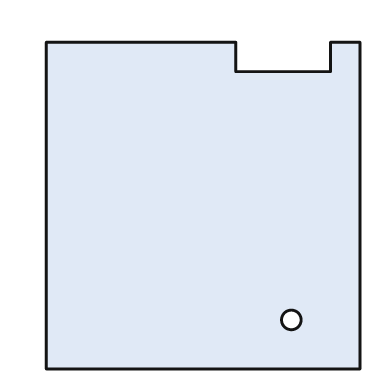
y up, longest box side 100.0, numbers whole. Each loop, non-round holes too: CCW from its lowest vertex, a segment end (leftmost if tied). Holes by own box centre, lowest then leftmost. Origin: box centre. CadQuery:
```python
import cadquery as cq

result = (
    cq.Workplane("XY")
    .moveTo(-48.0, -50.0)
    .lineTo(48.0, -50.0)
    .lineTo(48.0, 50.0)
    .lineTo(39.0, 50.0)
    .lineTo(39.0, 41.0)
    .lineTo(10.0, 41.0)
    .lineTo(10.0, 50.0)
    .lineTo(-48.0, 50.0)
    .close()
    .moveTo(27.0, -35.0)
    .circle(3.0)
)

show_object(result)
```